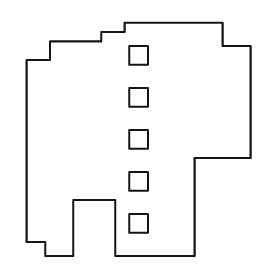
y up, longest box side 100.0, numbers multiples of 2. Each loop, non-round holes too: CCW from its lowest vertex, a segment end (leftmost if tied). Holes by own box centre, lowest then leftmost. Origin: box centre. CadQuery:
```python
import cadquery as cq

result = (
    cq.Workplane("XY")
    .moveTo(-40.0, -50.0)
    .lineTo(-28.0, -50.0)
    .lineTo(-28.0, -26.0)
    .lineTo(-10.0, -26.0)
    .lineTo(-10.0, -50.0)
    .lineTo(24.0, -50.0)
    .lineTo(24.0, -8.0)
    .lineTo(48.0, -8.0)
    .lineTo(48.0, 40.0)
    .lineTo(36.0, 40.0)
    .lineTo(36.0, 50.0)
    .lineTo(-6.0, 50.0)
    .lineTo(-6.0, 46.0)
    .lineTo(-16.0, 46.0)
    .lineTo(-16.0, 42.0)
    .lineTo(-38.0, 42.0)
    .lineTo(-38.0, 34.0)
    .lineTo(-48.0, 34.0)
    .lineTo(-48.0, -44.0)
    .lineTo(-40.0, -44.0)
    .close()
    .moveTo(-4.0, -40.0)
    .lineTo(4.0, -40.0)
    .lineTo(4.0, -32.0)
    .lineTo(-4.0, -32.0)
    .close()
    .moveTo(-4.0, -22.0)
    .lineTo(4.0, -22.0)
    .lineTo(4.0, -14.0)
    .lineTo(-4.0, -14.0)
    .close()
    .moveTo(-4.0, -4.0)
    .lineTo(4.0, -4.0)
    .lineTo(4.0, 4.0)
    .lineTo(-4.0, 4.0)
    .close()
    .moveTo(-4.0, 14.0)
    .lineTo(4.0, 14.0)
    .lineTo(4.0, 22.0)
    .lineTo(-4.0, 22.0)
    .close()
    .moveTo(-4.0, 32.0)
    .lineTo(4.0, 32.0)
    .lineTo(4.0, 40.0)
    .lineTo(-4.0, 40.0)
    .close()
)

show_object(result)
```